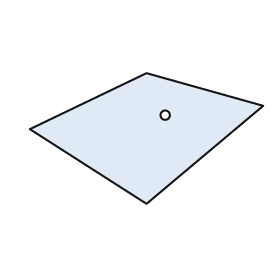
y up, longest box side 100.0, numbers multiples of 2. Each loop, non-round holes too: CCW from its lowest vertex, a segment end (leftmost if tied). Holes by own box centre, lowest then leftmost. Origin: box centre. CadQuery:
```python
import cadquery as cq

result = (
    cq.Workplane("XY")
    .moveTo(0.0, -28.0)
    .lineTo(50.0, 14.0)
    .lineTo(0.0, 28.0)
    .lineTo(-50.0, 4.0)
    .close()
    .moveTo(8.0, 10.0)
    .circle(2.0)
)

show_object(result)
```